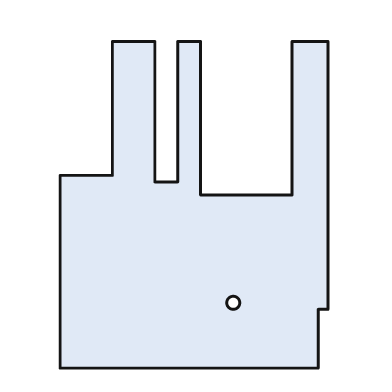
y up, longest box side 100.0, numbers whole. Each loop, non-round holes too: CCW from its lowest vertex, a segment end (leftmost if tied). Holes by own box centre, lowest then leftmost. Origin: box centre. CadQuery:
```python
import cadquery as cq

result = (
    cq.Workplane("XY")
    .moveTo(-41.0, -50.0)
    .lineTo(38.0, -50.0)
    .lineTo(38.0, -32.0)
    .lineTo(41.0, -32.0)
    .lineTo(41.0, 50.0)
    .lineTo(30.0, 50.0)
    .lineTo(30.0, 3.0)
    .lineTo(2.0, 3.0)
    .lineTo(2.0, 50.0)
    .lineTo(-5.0, 50.0)
    .lineTo(-5.0, 7.0)
    .lineTo(-12.0, 7.0)
    .lineTo(-12.0, 50.0)
    .lineTo(-25.0, 50.0)
    .lineTo(-25.0, 9.0)
    .lineTo(-41.0, 9.0)
    .close()
    .moveTo(12.0, -30.0)
    .circle(2.0)
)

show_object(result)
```